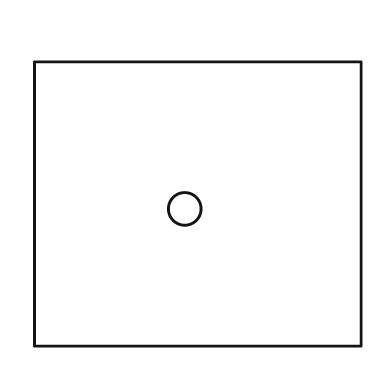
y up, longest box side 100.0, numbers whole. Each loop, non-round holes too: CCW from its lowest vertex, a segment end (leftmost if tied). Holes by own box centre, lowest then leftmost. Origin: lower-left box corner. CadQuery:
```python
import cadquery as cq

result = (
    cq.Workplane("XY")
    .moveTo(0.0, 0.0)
    .lineTo(100.0, 0.0)
    .lineTo(100.0, 87.0)
    .lineTo(0.0, 87.0)
    .close()
    .moveTo(46.0, 42.0)
    .circle(5.0)
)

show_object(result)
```